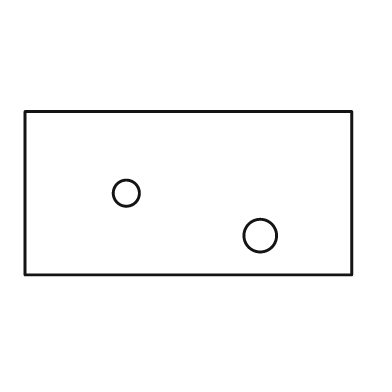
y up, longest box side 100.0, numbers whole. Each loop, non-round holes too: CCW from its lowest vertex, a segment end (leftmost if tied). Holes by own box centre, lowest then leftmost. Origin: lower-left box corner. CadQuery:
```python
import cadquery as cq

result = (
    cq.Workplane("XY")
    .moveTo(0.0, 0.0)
    .lineTo(100.0, 0.0)
    .lineTo(100.0, 50.0)
    .lineTo(0.0, 50.0)
    .close()
    .moveTo(72.0, 12.0)
    .circle(5.0)
    .moveTo(31.0, 25.0)
    .circle(4.0)
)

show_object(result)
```